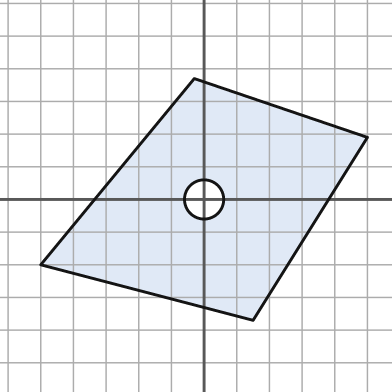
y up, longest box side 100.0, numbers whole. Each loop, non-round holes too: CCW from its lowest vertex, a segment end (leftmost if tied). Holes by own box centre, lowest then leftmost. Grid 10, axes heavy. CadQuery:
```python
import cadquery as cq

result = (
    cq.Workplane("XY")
    .moveTo(15.0, -37.0)
    .lineTo(50.0, 19.0)
    .lineTo(-3.0, 37.0)
    .lineTo(-50.0, -20.0)
    .close()
    .moveTo(0.0, 0.0)
    .circle(6.0)
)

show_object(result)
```